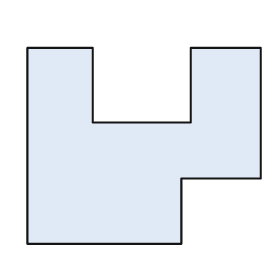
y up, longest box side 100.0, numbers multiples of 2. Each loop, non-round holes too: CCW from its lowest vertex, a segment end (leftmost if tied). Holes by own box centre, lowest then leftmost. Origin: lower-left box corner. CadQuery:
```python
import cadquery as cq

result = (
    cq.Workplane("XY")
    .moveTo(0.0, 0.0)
    .lineTo(66.0, 0.0)
    .lineTo(66.0, 28.0)
    .lineTo(100.0, 28.0)
    .lineTo(100.0, 84.0)
    .lineTo(70.0, 84.0)
    .lineTo(70.0, 52.0)
    .lineTo(28.0, 52.0)
    .lineTo(28.0, 84.0)
    .lineTo(0.0, 84.0)
    .close()
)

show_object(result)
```